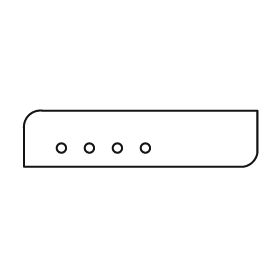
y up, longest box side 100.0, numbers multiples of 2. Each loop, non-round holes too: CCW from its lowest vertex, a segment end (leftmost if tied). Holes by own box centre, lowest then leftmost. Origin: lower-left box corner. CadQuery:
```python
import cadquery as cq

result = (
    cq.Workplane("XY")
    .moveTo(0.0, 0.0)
    .lineTo(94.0, 0.0)
    .threePointArc((98.0, 2.0), (100.0, 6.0))
    .lineTo(100.0, 24.0)
    .lineTo(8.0, 24.0)
    .threePointArc((2.0, 22.0), (0.0, 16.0))
    .close()
    .moveTo(16.0, 8.0)
    .circle(2.0)
    .moveTo(28.0, 8.0)
    .circle(2.0)
    .moveTo(40.0, 8.0)
    .circle(2.0)
    .moveTo(52.0, 8.0)
    .circle(2.0)
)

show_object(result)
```